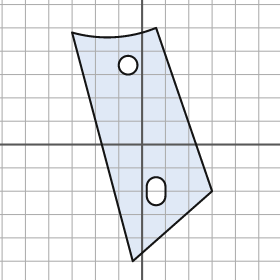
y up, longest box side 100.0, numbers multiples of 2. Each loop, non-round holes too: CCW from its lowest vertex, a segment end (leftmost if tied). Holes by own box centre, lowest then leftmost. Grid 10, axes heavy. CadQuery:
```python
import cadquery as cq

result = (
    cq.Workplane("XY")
    .moveTo(-4.0, -50.0)
    .lineTo(30.0, -20.0)
    .lineTo(6.0, 50.0)
    .threePointArc((-12.0, 46.0), (-30.0, 48.0))
    .close()
    .moveTo(2.0, -22.0)
    .threePointArc((6.0, -26.0), (10.0, -22.0))
    .lineTo(10.0, -18.0)
    .threePointArc((6.0, -14.0), (2.0, -18.0))
    .close()
    .moveTo(-6.0, 34.0)
    .circle(4.0)
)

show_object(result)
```